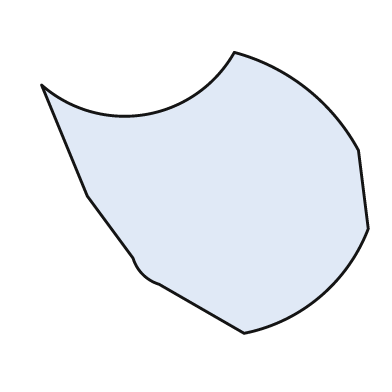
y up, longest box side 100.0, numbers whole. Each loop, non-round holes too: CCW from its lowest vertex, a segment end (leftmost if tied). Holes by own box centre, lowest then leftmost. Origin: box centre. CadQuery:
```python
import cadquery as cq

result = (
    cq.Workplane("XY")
    .moveTo(12.0, -43.0)
    .threePointArc((35.0, -32.0), (50.0, -11.0))
    .lineTo(47.0, 13.0)
    .threePointArc((31.0, 32.0), (9.0, 43.0))
    .threePointArc((-18.0, 24.0), (-50.0, 33.0))
    .lineTo(-36.0, -1.0)
    .lineTo(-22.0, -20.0)
    .threePointArc((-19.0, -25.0), (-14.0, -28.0))
    .close()
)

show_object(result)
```